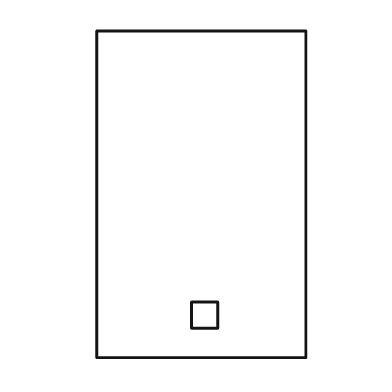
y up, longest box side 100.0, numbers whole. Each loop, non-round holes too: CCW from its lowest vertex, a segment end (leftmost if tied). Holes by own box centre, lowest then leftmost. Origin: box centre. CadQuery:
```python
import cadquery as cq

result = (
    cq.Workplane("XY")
    .moveTo(-32.0, -50.0)
    .lineTo(32.0, -50.0)
    .lineTo(32.0, 50.0)
    .lineTo(-32.0, 50.0)
    .close()
    .moveTo(-3.0, -41.0)
    .lineTo(5.0, -41.0)
    .lineTo(5.0, -33.0)
    .lineTo(-3.0, -33.0)
    .close()
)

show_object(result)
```